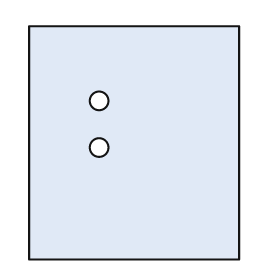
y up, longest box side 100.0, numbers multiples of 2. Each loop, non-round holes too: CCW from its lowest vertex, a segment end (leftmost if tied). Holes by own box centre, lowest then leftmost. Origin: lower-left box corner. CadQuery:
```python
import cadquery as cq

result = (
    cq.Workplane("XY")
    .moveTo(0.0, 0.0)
    .lineTo(90.0, 0.0)
    .lineTo(90.0, 100.0)
    .lineTo(0.0, 100.0)
    .close()
    .moveTo(30.0, 48.0)
    .circle(4.0)
    .moveTo(30.0, 68.0)
    .circle(4.0)
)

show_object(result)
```